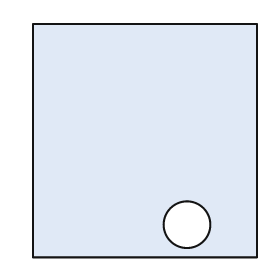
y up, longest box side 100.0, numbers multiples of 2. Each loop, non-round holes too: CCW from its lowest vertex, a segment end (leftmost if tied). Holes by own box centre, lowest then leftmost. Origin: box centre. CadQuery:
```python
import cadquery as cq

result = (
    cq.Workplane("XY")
    .moveTo(-48.0, -50.0)
    .lineTo(48.0, -50.0)
    .lineTo(48.0, 50.0)
    .lineTo(-48.0, 50.0)
    .close()
    .moveTo(18.0, -36.0)
    .circle(10.0)
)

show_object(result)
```